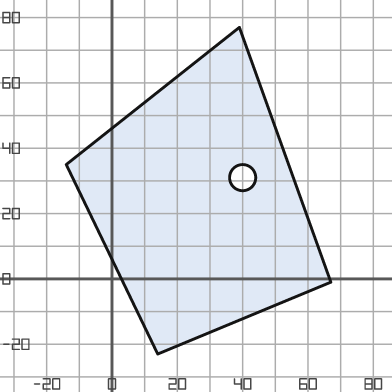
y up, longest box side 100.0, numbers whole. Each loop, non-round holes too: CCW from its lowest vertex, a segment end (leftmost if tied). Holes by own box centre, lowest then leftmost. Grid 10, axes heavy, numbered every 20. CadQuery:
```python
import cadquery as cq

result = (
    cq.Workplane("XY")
    .moveTo(14.0, -23.0)
    .lineTo(67.0, -1.0)
    .lineTo(39.0, 77.0)
    .lineTo(-14.0, 35.0)
    .close()
    .moveTo(40.0, 31.0)
    .circle(4.0)
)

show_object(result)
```